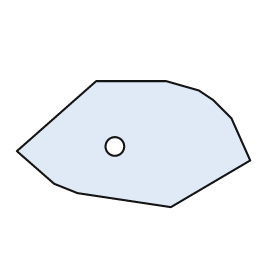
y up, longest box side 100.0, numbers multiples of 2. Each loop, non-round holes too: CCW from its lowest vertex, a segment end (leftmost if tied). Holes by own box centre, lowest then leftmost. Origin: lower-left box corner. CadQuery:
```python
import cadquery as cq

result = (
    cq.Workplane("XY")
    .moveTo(66.0, 0.0)
    .lineTo(100.0, 20.0)
    .lineTo(92.0, 38.0)
    .lineTo(84.0, 46.0)
    .lineTo(78.0, 50.0)
    .lineTo(64.0, 54.0)
    .lineTo(34.0, 54.0)
    .lineTo(0.0, 24.0)
    .lineTo(16.0, 10.0)
    .lineTo(26.0, 6.0)
    .close()
    .moveTo(42.0, 26.0)
    .circle(4.0)
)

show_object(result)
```